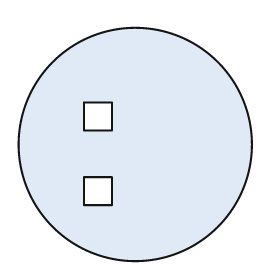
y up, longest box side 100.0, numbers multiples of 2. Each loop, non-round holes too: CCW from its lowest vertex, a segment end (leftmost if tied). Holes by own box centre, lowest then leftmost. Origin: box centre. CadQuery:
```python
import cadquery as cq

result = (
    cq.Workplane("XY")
    .moveTo(0.0, 0.0)
    .circle(50.0)
    .moveTo(-22.0, -26.0)
    .lineTo(-10.0, -26.0)
    .lineTo(-10.0, -14.0)
    .lineTo(-22.0, -14.0)
    .close()
    .moveTo(-22.0, 6.0)
    .lineTo(-10.0, 6.0)
    .lineTo(-10.0, 18.0)
    .lineTo(-22.0, 18.0)
    .close()
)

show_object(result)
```